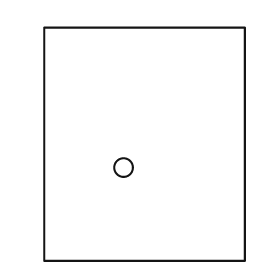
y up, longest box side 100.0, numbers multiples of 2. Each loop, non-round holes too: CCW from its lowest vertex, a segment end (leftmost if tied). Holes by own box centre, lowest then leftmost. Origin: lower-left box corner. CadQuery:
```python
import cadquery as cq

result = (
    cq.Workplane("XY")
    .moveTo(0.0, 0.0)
    .lineTo(86.0, 0.0)
    .lineTo(86.0, 100.0)
    .lineTo(0.0, 100.0)
    .close()
    .moveTo(34.0, 40.0)
    .circle(4.0)
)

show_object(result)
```